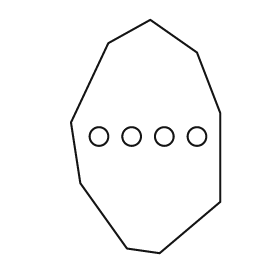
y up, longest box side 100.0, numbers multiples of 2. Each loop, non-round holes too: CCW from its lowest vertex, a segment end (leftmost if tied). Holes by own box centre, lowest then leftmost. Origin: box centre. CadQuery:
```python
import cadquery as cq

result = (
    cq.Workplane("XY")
    .moveTo(6.0, -50.0)
    .lineTo(32.0, -28.0)
    .lineTo(32.0, 10.0)
    .lineTo(22.0, 36.0)
    .lineTo(2.0, 50.0)
    .lineTo(-16.0, 40.0)
    .lineTo(-32.0, 6.0)
    .lineTo(-28.0, -20.0)
    .lineTo(-8.0, -48.0)
    .close()
    .moveTo(-20.0, 0.0)
    .circle(4.0)
    .moveTo(-6.0, 0.0)
    .circle(4.0)
    .moveTo(8.0, 0.0)
    .circle(4.0)
    .moveTo(22.0, 0.0)
    .circle(4.0)
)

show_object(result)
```